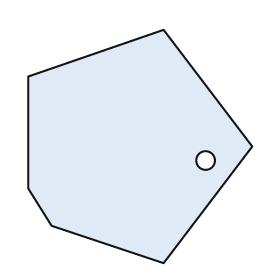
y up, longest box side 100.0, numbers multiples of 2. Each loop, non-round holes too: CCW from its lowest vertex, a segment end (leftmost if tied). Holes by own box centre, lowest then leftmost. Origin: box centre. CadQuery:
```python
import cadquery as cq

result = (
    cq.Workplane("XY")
    .moveTo(10.0, -50.0)
    .lineTo(48.0, 0.0)
    .lineTo(10.0, 50.0)
    .lineTo(-48.0, 30.0)
    .lineTo(-48.0, -18.0)
    .lineTo(-38.0, -34.0)
    .close()
    .moveTo(28.0, -6.0)
    .circle(4.0)
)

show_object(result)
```